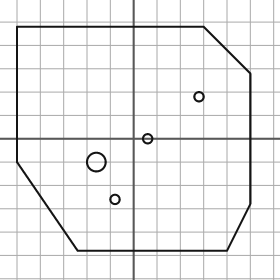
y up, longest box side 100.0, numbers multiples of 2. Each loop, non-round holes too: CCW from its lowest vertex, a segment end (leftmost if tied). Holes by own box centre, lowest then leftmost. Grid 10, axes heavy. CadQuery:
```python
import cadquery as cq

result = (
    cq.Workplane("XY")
    .moveTo(-24.0, -48.0)
    .lineTo(40.0, -48.0)
    .lineTo(50.0, -28.0)
    .lineTo(50.0, 28.0)
    .lineTo(30.0, 48.0)
    .lineTo(-50.0, 48.0)
    .lineTo(-50.0, -10.0)
    .close()
    .moveTo(-8.0, -26.0)
    .circle(2.0)
    .moveTo(-16.0, -10.0)
    .circle(4.0)
    .moveTo(6.0, 0.0)
    .circle(2.0)
    .moveTo(28.0, 18.0)
    .circle(2.0)
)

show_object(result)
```